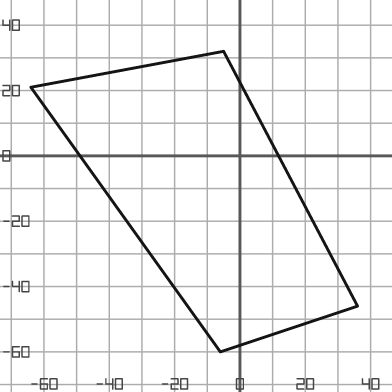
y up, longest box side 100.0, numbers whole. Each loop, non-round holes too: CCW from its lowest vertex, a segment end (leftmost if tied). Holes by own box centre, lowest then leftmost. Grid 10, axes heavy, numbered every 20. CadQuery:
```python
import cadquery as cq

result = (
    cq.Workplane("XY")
    .moveTo(-6.0, -60.0)
    .lineTo(36.0, -46.0)
    .lineTo(-5.0, 32.0)
    .lineTo(-64.0, 21.0)
    .close()
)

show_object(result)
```